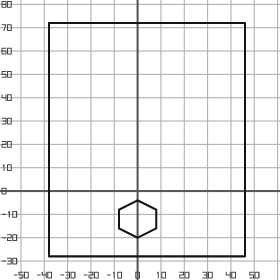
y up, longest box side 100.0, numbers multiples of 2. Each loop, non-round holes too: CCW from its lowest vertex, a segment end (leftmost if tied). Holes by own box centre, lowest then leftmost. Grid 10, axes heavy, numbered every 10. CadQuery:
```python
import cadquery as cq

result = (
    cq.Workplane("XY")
    .moveTo(-38.0, -28.0)
    .lineTo(46.0, -28.0)
    .lineTo(46.0, 72.0)
    .lineTo(-38.0, 72.0)
    .close()
    .moveTo(0.0, -20.0)
    .lineTo(8.0, -16.0)
    .lineTo(8.0, -8.0)
    .lineTo(0.0, -4.0)
    .lineTo(-8.0, -8.0)
    .lineTo(-8.0, -16.0)
    .close()
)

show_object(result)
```